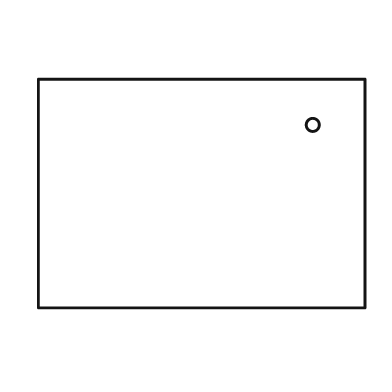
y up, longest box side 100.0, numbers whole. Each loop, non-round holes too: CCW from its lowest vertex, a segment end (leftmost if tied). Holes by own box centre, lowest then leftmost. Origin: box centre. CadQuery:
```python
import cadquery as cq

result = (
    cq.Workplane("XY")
    .moveTo(-50.0, -35.0)
    .lineTo(50.0, -35.0)
    .lineTo(50.0, 35.0)
    .lineTo(-50.0, 35.0)
    .close()
    .moveTo(34.0, 21.0)
    .circle(2.0)
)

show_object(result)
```